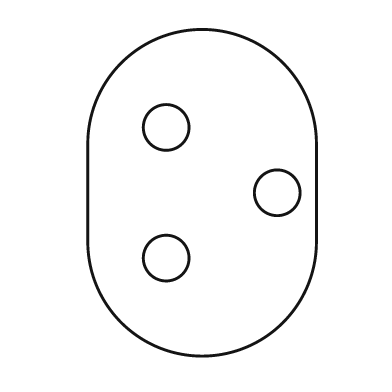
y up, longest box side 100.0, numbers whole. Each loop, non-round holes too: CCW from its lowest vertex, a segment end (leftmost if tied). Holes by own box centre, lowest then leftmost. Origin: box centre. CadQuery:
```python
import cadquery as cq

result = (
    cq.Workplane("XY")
    .moveTo(-35.0, -15.0)
    .threePointArc((0.0, -50.0), (35.0, -15.0))
    .lineTo(35.0, 15.0)
    .threePointArc((0.0, 50.0), (-35.0, 15.0))
    .close()
    .moveTo(-11.0, -20.0)
    .circle(7.0)
    .moveTo(23.0, 0.0)
    .circle(7.0)
    .moveTo(-11.0, 20.0)
    .circle(7.0)
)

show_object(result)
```